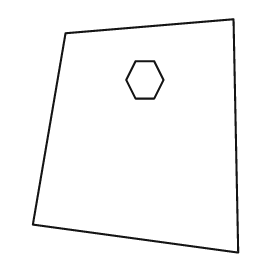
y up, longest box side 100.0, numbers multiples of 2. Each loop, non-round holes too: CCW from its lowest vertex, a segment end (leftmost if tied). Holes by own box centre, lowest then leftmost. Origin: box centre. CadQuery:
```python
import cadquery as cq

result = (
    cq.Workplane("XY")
    .moveTo(44.0, -50.0)
    .lineTo(42.0, 50.0)
    .lineTo(-30.0, 44.0)
    .lineTo(-44.0, -38.0)
    .close()
    .moveTo(0.0, 16.0)
    .lineTo(8.0, 16.0)
    .lineTo(12.0, 24.0)
    .lineTo(8.0, 32.0)
    .lineTo(0.0, 32.0)
    .lineTo(-4.0, 24.0)
    .close()
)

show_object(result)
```